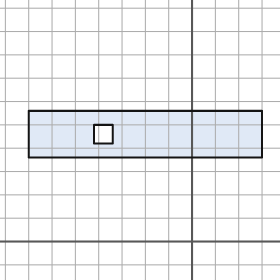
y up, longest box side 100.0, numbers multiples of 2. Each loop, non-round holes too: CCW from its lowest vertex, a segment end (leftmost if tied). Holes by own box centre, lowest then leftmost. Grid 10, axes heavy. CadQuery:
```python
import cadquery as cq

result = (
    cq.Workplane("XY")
    .moveTo(-70.0, 36.0)
    .lineTo(30.0, 36.0)
    .lineTo(30.0, 56.0)
    .lineTo(-70.0, 56.0)
    .close()
    .moveTo(-42.0, 42.0)
    .lineTo(-34.0, 42.0)
    .lineTo(-34.0, 50.0)
    .lineTo(-42.0, 50.0)
    .close()
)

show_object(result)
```